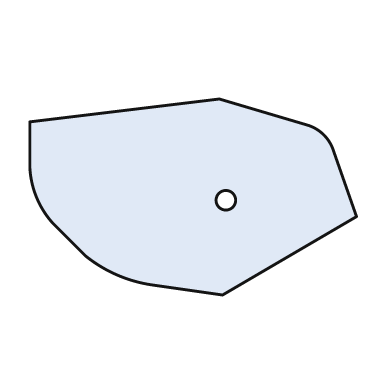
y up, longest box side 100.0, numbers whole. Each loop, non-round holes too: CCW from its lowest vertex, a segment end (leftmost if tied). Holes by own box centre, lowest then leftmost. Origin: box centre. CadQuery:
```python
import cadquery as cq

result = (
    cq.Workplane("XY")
    .moveTo(9.0, -30.0)
    .lineTo(50.0, -6.0)
    .lineTo(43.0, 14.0)
    .threePointArc((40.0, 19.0), (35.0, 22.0))
    .lineTo(8.0, 30.0)
    .lineTo(-50.0, 23.0)
    .lineTo(-50.0, 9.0)
    .threePointArc((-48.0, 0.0), (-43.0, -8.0))
    .lineTo(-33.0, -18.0)
    .threePointArc((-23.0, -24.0), (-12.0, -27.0))
    .close()
    .moveTo(10.0, -1.0)
    .circle(3.0)
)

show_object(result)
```